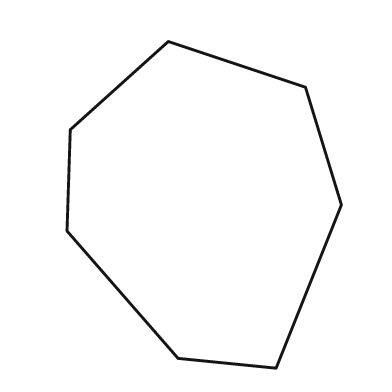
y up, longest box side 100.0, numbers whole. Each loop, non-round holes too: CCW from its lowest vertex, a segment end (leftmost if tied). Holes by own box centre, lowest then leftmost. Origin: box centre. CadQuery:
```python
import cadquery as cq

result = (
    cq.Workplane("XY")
    .moveTo(22.0, -50.0)
    .lineTo(42.0, 0.0)
    .lineTo(31.0, 36.0)
    .lineTo(-11.0, 50.0)
    .lineTo(-41.0, 23.0)
    .lineTo(-42.0, -8.0)
    .lineTo(-8.0, -47.0)
    .close()
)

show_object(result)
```